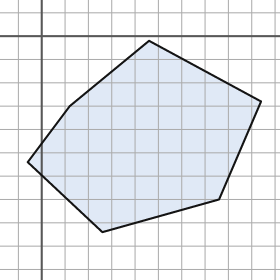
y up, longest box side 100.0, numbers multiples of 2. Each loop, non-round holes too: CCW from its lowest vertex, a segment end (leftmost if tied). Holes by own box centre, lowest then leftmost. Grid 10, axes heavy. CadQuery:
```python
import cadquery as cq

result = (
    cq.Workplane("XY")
    .moveTo(26.0, -84.0)
    .lineTo(76.0, -70.0)
    .lineTo(94.0, -28.0)
    .lineTo(46.0, -2.0)
    .lineTo(12.0, -30.0)
    .lineTo(-6.0, -54.0)
    .close()
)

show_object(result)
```